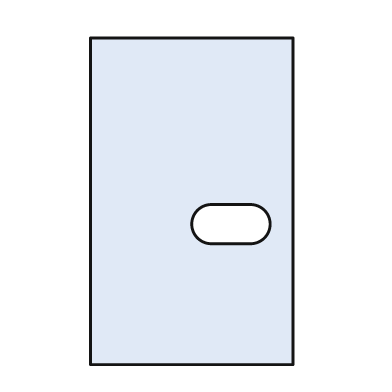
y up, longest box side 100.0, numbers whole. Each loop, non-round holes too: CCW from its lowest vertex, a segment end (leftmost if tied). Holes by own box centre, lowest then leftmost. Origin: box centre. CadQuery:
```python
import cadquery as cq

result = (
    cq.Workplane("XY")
    .moveTo(-31.0, -50.0)
    .lineTo(31.0, -50.0)
    .lineTo(31.0, 50.0)
    .lineTo(-31.0, 50.0)
    .close()
    .moveTo(6.0, -13.0)
    .lineTo(18.0, -13.0)
    .threePointArc((24.0, -7.0), (18.0, -1.0))
    .lineTo(6.0, -1.0)
    .threePointArc((0.0, -7.0), (6.0, -13.0))
    .close()
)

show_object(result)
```